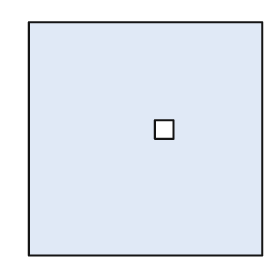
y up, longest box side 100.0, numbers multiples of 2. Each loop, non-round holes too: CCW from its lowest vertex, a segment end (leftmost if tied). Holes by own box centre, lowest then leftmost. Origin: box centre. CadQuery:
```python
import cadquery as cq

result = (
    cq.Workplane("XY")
    .moveTo(-50.0, -50.0)
    .lineTo(50.0, -50.0)
    .lineTo(50.0, 50.0)
    .lineTo(-50.0, 50.0)
    .close()
    .moveTo(4.0, 0.0)
    .lineTo(12.0, 0.0)
    .lineTo(12.0, 8.0)
    .lineTo(4.0, 8.0)
    .close()
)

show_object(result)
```